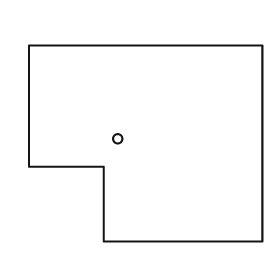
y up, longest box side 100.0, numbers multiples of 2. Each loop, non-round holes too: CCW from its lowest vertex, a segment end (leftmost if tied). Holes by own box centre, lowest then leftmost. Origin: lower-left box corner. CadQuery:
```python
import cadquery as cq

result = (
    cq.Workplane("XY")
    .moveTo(32.0, 0.0)
    .lineTo(100.0, 0.0)
    .lineTo(100.0, 84.0)
    .lineTo(0.0, 84.0)
    .lineTo(0.0, 32.0)
    .lineTo(32.0, 32.0)
    .close()
    .moveTo(38.0, 44.0)
    .circle(2.0)
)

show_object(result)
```